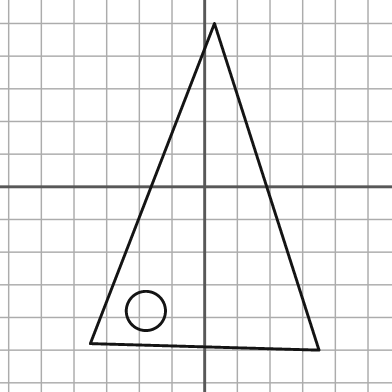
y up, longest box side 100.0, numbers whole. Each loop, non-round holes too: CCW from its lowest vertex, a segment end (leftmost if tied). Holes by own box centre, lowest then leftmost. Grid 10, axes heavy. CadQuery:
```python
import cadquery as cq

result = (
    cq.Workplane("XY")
    .moveTo(35.0, -50.0)
    .lineTo(3.0, 50.0)
    .lineTo(-35.0, -48.0)
    .close()
    .moveTo(-18.0, -38.0)
    .circle(6.0)
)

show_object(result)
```